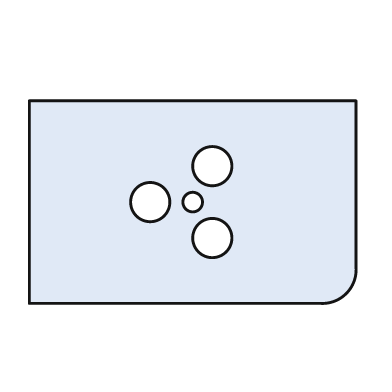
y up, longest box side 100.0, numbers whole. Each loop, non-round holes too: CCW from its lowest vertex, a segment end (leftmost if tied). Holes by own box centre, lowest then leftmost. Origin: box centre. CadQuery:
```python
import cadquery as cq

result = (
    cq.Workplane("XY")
    .moveTo(-50.0, -31.0)
    .lineTo(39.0, -31.0)
    .threePointArc((47.0, -28.0), (50.0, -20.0))
    .lineTo(50.0, 31.0)
    .lineTo(-50.0, 31.0)
    .close()
    .moveTo(6.0, -11.0)
    .circle(6.0)
    .moveTo(-13.0, 0.0)
    .circle(6.0)
    .moveTo(0.0, 0.0)
    .circle(3.0)
    .moveTo(6.0, 11.0)
    .circle(6.0)
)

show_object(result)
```